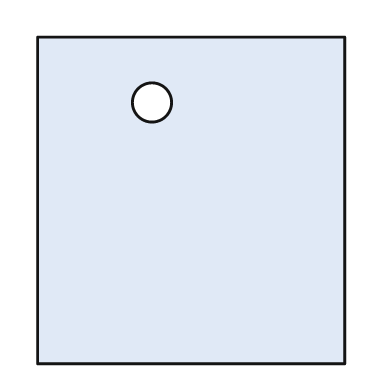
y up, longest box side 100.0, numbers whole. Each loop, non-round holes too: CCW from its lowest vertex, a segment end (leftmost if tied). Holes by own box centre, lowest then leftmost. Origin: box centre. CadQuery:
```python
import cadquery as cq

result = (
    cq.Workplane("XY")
    .moveTo(-47.0, -50.0)
    .lineTo(47.0, -50.0)
    .lineTo(47.0, 50.0)
    .lineTo(-47.0, 50.0)
    .close()
    .moveTo(-12.0, 30.0)
    .circle(6.0)
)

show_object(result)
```